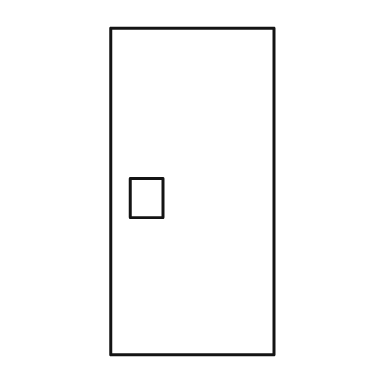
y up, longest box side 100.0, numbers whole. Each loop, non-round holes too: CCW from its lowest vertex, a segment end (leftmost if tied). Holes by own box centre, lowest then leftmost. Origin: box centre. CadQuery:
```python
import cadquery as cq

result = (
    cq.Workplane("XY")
    .moveTo(-25.0, -50.0)
    .lineTo(25.0, -50.0)
    .lineTo(25.0, 50.0)
    .lineTo(-25.0, 50.0)
    .close()
    .moveTo(-19.0, -8.0)
    .lineTo(-9.0, -8.0)
    .lineTo(-9.0, 4.0)
    .lineTo(-19.0, 4.0)
    .close()
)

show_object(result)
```